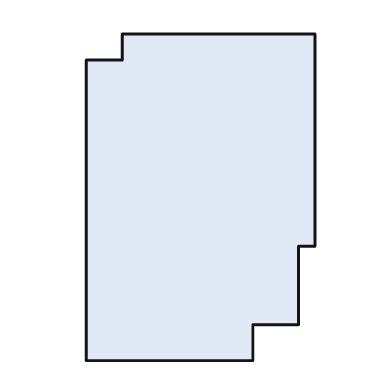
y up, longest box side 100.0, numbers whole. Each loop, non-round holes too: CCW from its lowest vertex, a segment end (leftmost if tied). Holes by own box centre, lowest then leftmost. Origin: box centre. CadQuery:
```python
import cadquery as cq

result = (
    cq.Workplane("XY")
    .moveTo(-35.0, -50.0)
    .lineTo(16.0, -50.0)
    .lineTo(16.0, -39.0)
    .lineTo(30.0, -39.0)
    .lineTo(30.0, -15.0)
    .lineTo(35.0, -15.0)
    .lineTo(35.0, 50.0)
    .lineTo(-24.0, 50.0)
    .lineTo(-24.0, 42.0)
    .lineTo(-35.0, 42.0)
    .close()
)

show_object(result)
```